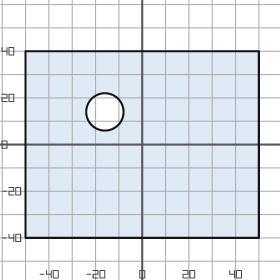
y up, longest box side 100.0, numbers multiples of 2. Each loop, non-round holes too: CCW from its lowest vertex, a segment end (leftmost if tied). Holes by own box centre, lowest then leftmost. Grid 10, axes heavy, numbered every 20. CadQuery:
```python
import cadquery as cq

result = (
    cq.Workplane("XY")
    .moveTo(-50.0, -40.0)
    .lineTo(50.0, -40.0)
    .lineTo(50.0, 40.0)
    .lineTo(-50.0, 40.0)
    .close()
    .moveTo(-16.0, 14.0)
    .circle(8.0)
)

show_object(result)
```